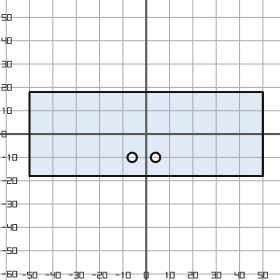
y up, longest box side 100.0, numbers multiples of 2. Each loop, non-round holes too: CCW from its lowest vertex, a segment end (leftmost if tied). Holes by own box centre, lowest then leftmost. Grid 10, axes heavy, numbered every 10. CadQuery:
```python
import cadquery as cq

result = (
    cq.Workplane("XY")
    .moveTo(-50.0, -18.0)
    .lineTo(50.0, -18.0)
    .lineTo(50.0, 18.0)
    .lineTo(-50.0, 18.0)
    .close()
    .moveTo(-6.0, -10.0)
    .circle(2.0)
    .moveTo(4.0, -10.0)
    .circle(2.0)
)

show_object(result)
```